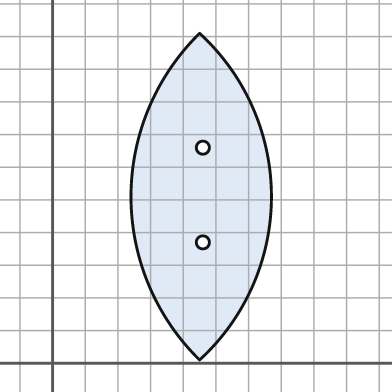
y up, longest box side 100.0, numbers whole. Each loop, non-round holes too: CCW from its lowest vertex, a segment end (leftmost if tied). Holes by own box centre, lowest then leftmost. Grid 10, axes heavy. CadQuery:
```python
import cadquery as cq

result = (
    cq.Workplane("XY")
    .moveTo(45.0, 1.0)
    .threePointArc((67.0, 51.0), (45.0, 101.0))
    .threePointArc((24.0, 51.0), (45.0, 1.0))
    .close()
    .moveTo(46.0, 37.0)
    .circle(2.0)
    .moveTo(46.0, 66.0)
    .circle(2.0)
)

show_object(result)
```